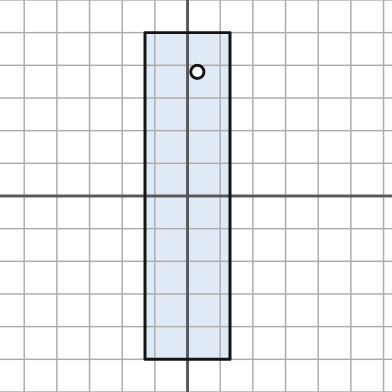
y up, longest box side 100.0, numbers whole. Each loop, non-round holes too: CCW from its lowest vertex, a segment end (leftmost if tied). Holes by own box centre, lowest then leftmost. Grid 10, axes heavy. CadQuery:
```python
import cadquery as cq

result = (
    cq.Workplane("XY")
    .moveTo(-13.0, -50.0)
    .lineTo(13.0, -50.0)
    .lineTo(13.0, 50.0)
    .lineTo(-13.0, 50.0)
    .close()
    .moveTo(3.0, 38.0)
    .circle(2.0)
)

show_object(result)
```